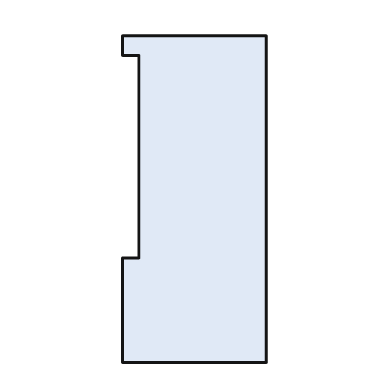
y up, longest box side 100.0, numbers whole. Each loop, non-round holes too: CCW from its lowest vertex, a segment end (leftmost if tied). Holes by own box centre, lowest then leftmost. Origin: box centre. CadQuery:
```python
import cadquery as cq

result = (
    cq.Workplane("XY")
    .moveTo(-22.0, -50.0)
    .lineTo(22.0, -50.0)
    .lineTo(22.0, 50.0)
    .lineTo(-22.0, 50.0)
    .lineTo(-22.0, 44.0)
    .lineTo(-17.0, 44.0)
    .lineTo(-17.0, -18.0)
    .lineTo(-22.0, -18.0)
    .close()
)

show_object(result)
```